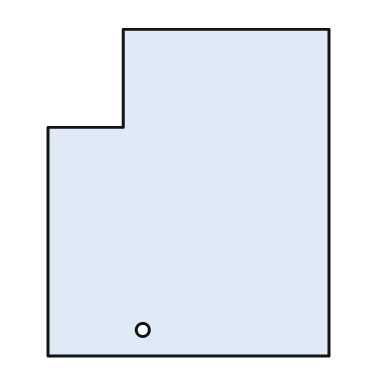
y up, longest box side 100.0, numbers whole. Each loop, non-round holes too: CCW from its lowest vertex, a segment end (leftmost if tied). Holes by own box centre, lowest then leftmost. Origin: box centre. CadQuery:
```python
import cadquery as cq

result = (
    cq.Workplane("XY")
    .moveTo(-43.0, -50.0)
    .lineTo(43.0, -50.0)
    .lineTo(43.0, 50.0)
    .lineTo(-20.0, 50.0)
    .lineTo(-20.0, 20.0)
    .lineTo(-43.0, 20.0)
    .close()
    .moveTo(-14.0, -42.0)
    .circle(2.0)
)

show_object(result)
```